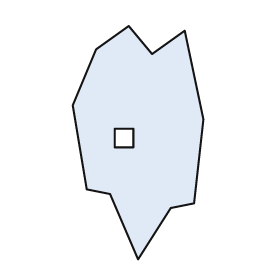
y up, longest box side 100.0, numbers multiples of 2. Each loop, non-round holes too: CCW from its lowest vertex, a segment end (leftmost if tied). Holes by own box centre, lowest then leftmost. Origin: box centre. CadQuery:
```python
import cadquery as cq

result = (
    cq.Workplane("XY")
    .moveTo(0.0, -50.0)
    .lineTo(14.0, -28.0)
    .lineTo(24.0, -26.0)
    .lineTo(28.0, 10.0)
    .lineTo(20.0, 48.0)
    .lineTo(6.0, 38.0)
    .lineTo(-4.0, 50.0)
    .lineTo(-18.0, 40.0)
    .lineTo(-28.0, 16.0)
    .lineTo(-22.0, -20.0)
    .lineTo(-12.0, -22.0)
    .close()
    .moveTo(-10.0, -2.0)
    .lineTo(-2.0, -2.0)
    .lineTo(-2.0, 6.0)
    .lineTo(-10.0, 6.0)
    .close()
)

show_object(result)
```